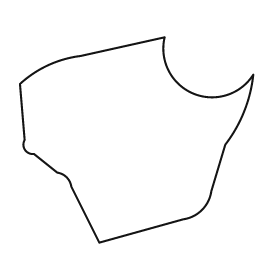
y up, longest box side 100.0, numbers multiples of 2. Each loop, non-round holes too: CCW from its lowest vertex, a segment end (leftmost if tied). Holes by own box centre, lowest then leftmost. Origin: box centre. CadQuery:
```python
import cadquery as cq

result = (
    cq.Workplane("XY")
    .moveTo(-16.0, -44.0)
    .lineTo(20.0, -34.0)
    .threePointArc((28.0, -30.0), (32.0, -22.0))
    .lineTo(38.0, -2.0)
    .threePointArc((46.0, 12.0), (50.0, 28.0))
    .threePointArc((24.0, 20.0), (12.0, 44.0))
    .lineTo(-24.0, 36.0)
    .threePointArc((-38.0, 32.0), (-50.0, 24.0))
    .lineTo(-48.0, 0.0)
    .threePointArc((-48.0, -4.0), (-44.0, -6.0))
    .lineTo(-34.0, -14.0)
    .threePointArc((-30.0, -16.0), (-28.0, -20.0))
    .close()
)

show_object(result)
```